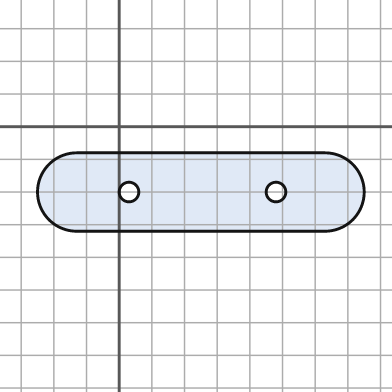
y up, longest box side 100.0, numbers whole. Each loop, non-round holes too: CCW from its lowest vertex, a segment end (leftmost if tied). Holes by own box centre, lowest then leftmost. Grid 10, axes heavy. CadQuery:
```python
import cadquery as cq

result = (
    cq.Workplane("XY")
    .moveTo(-13.0, -32.0)
    .lineTo(63.0, -32.0)
    .threePointArc((75.0, -20.0), (63.0, -8.0))
    .lineTo(-13.0, -8.0)
    .threePointArc((-25.0, -20.0), (-13.0, -32.0))
    .close()
    .moveTo(3.0, -20.0)
    .circle(3.0)
    .moveTo(48.0, -20.0)
    .circle(3.0)
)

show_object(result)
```